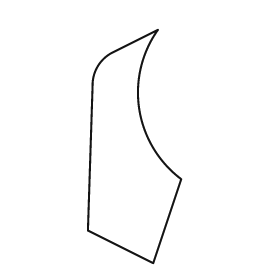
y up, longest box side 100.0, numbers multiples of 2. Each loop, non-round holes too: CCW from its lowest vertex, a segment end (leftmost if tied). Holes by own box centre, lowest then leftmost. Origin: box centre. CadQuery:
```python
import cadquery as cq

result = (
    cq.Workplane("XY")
    .moveTo(8.0, -50.0)
    .lineTo(20.0, -14.0)
    .threePointArc((2.0, 16.0), (10.0, 50.0))
    .lineTo(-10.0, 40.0)
    .threePointArc((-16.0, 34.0), (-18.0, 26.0))
    .lineTo(-20.0, -36.0)
    .close()
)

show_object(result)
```